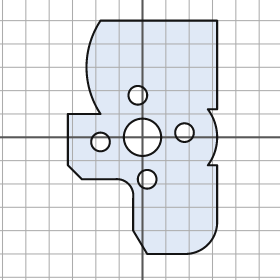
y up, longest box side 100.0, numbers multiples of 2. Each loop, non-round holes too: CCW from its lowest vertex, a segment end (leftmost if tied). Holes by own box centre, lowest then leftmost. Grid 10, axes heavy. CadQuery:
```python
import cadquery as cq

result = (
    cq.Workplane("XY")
    .moveTo(2.0, -50.0)
    .lineTo(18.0, -50.0)
    .threePointArc((28.0, -46.0), (32.0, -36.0))
    .lineTo(32.0, -12.0)
    .lineTo(28.0, -12.0)
    .threePointArc((32.0, 0.0), (28.0, 12.0))
    .lineTo(32.0, 12.0)
    .lineTo(32.0, 50.0)
    .lineTo(-18.0, 50.0)
    .threePointArc((-24.0, 30.0), (-18.0, 10.0))
    .lineTo(-32.0, 10.0)
    .lineTo(-32.0, -12.0)
    .lineTo(-26.0, -18.0)
    .lineTo(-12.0, -18.0)
    .threePointArc((-6.0, -20.0), (-4.0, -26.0))
    .lineTo(-4.0, -40.0)
    .close()
    .moveTo(2.0, -18.0)
    .circle(4.0)
    .moveTo(-18.0, -2.0)
    .circle(4.0)
    .moveTo(0.0, 0.0)
    .circle(8.0)
    .moveTo(18.0, 2.0)
    .circle(4.0)
    .moveTo(-2.0, 18.0)
    .circle(4.0)
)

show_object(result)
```